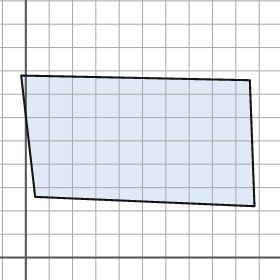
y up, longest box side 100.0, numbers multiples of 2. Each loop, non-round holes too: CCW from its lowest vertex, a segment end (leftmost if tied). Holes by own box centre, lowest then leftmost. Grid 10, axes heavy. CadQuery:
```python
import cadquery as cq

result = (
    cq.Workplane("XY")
    .moveTo(98.0, 22.0)
    .lineTo(96.0, 76.0)
    .lineTo(-2.0, 78.0)
    .lineTo(4.0, 26.0)
    .close()
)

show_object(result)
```